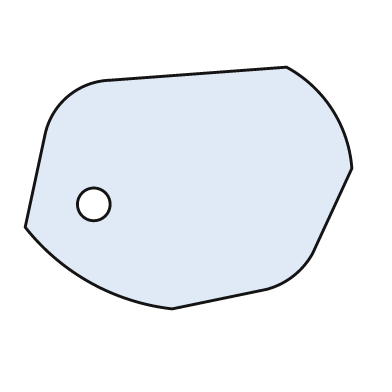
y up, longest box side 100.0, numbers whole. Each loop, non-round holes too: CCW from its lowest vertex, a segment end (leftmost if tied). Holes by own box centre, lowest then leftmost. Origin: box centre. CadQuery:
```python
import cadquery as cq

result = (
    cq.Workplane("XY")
    .moveTo(-5.0, -37.0)
    .lineTo(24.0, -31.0)
    .threePointArc((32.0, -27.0), (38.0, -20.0))
    .lineTo(50.0, 6.0)
    .threePointArc((44.0, 24.0), (30.0, 37.0))
    .lineTo(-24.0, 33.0)
    .threePointArc((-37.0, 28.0), (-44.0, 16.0))
    .lineTo(-50.0, -12.0)
    .threePointArc((-30.0, -29.0), (-5.0, -37.0))
    .close()
    .moveTo(-29.0, -5.0)
    .circle(5.0)
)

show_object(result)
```